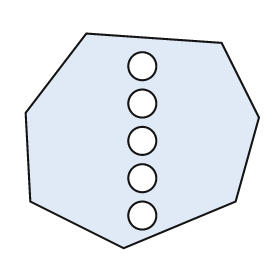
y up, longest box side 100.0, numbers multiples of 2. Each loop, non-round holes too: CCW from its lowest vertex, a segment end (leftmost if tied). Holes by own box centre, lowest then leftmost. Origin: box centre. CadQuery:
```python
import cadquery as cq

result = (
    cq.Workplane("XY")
    .moveTo(-8.0, -46.0)
    .lineTo(40.0, -26.0)
    .lineTo(50.0, 10.0)
    .lineTo(34.0, 42.0)
    .lineTo(-24.0, 46.0)
    .lineTo(-50.0, 12.0)
    .lineTo(-48.0, -26.0)
    .close()
    .moveTo(0.0, -32.0)
    .circle(6.0)
    .moveTo(0.0, -16.0)
    .circle(6.0)
    .moveTo(0.0, 0.0)
    .circle(6.0)
    .moveTo(0.0, 16.0)
    .circle(6.0)
    .moveTo(0.0, 32.0)
    .circle(6.0)
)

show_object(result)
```